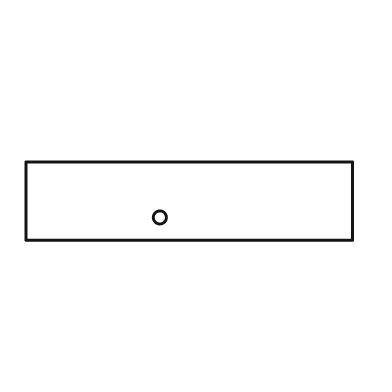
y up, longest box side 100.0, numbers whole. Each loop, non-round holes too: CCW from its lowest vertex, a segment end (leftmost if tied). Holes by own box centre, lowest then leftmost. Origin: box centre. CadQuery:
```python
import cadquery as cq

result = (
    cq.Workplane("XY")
    .moveTo(-50.0, -12.0)
    .lineTo(50.0, -12.0)
    .lineTo(50.0, 12.0)
    .lineTo(-50.0, 12.0)
    .close()
    .moveTo(-9.0, -5.0)
    .circle(2.0)
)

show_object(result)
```